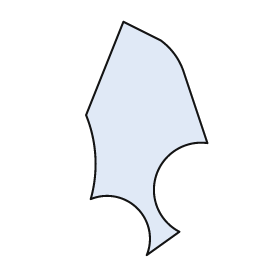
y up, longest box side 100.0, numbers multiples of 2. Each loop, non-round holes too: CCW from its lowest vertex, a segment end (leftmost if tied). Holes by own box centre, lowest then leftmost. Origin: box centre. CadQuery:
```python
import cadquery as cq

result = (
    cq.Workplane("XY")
    .moveTo(0.0, -50.0)
    .lineTo(14.0, -40.0)
    .threePointArc((4.0, -16.0), (26.0, -2.0))
    .lineTo(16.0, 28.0)
    .threePointArc((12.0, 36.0), (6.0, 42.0))
    .lineTo(-10.0, 50.0)
    .lineTo(-26.0, 10.0)
    .threePointArc((-22.0, -8.0), (-24.0, -26.0))
    .threePointArc((-4.0, -30.0), (0.0, -50.0))
    .close()
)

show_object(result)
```